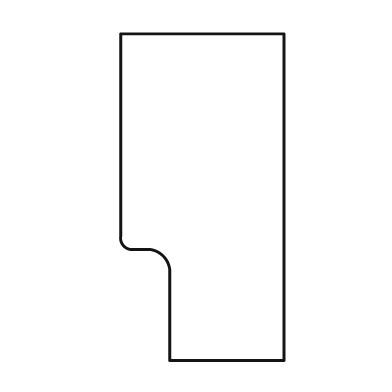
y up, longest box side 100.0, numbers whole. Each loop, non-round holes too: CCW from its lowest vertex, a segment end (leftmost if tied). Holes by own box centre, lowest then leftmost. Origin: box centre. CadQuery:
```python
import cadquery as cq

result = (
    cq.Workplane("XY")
    .moveTo(-10.0, -50.0)
    .lineTo(25.0, -50.0)
    .lineTo(25.0, 50.0)
    .lineTo(-25.0, 50.0)
    .lineTo(-25.0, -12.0)
    .threePointArc((-24.0, -15.0), (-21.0, -16.0))
    .lineTo(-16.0, -16.0)
    .threePointArc((-12.0, -18.0), (-10.0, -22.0))
    .close()
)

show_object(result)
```